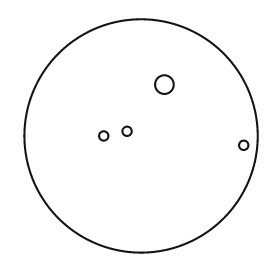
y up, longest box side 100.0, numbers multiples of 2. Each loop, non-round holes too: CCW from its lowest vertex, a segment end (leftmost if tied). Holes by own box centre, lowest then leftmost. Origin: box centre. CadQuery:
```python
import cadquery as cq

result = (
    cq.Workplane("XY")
    .moveTo(0.0, 0.0)
    .circle(50.0)
    .moveTo(44.0, -4.0)
    .circle(2.0)
    .moveTo(-16.0, 0.0)
    .circle(2.0)
    .moveTo(-6.0, 2.0)
    .circle(2.0)
    .moveTo(10.0, 22.0)
    .circle(4.0)
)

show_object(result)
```